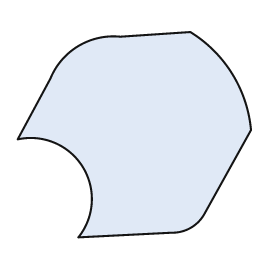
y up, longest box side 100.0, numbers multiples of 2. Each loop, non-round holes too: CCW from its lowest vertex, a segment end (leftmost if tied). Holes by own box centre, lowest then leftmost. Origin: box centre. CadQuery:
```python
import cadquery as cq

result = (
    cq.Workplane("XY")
    .moveTo(-24.0, -44.0)
    .lineTo(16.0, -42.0)
    .threePointArc((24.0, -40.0), (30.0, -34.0))
    .lineTo(50.0, 2.0)
    .threePointArc((42.0, 26.0), (24.0, 44.0))
    .lineTo(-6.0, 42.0)
    .threePointArc((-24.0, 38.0), (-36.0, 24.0))
    .lineTo(-50.0, -2.0)
    .threePointArc((-22.0, -14.0), (-24.0, -44.0))
    .close()
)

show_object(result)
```